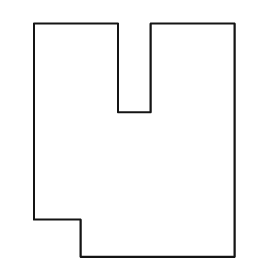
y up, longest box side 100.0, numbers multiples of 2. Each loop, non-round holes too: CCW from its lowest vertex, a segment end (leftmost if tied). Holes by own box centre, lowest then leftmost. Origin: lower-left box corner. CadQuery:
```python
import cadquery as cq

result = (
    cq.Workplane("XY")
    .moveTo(20.0, 0.0)
    .lineTo(86.0, 0.0)
    .lineTo(86.0, 100.0)
    .lineTo(50.0, 100.0)
    .lineTo(50.0, 62.0)
    .lineTo(36.0, 62.0)
    .lineTo(36.0, 100.0)
    .lineTo(0.0, 100.0)
    .lineTo(0.0, 16.0)
    .lineTo(20.0, 16.0)
    .close()
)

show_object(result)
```